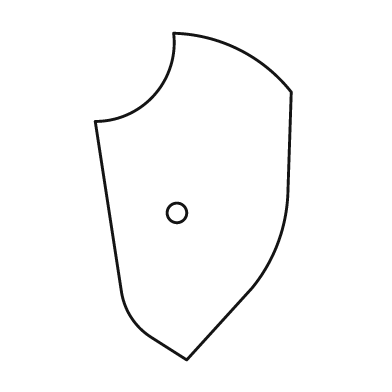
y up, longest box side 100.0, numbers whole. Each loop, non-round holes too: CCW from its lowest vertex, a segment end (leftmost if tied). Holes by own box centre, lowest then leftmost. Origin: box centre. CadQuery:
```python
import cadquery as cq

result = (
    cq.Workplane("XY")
    .moveTo(-2.0, -50.0)
    .lineTo(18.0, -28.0)
    .threePointArc((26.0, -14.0), (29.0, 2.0))
    .lineTo(30.0, 32.0)
    .threePointArc((14.0, 45.0), (-6.0, 50.0))
    .threePointArc((-12.0, 31.0), (-30.0, 23.0))
    .lineTo(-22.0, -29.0)
    .threePointArc((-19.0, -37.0), (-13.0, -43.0))
    .close()
    .moveTo(-5.0, -5.0)
    .circle(3.0)
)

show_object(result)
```